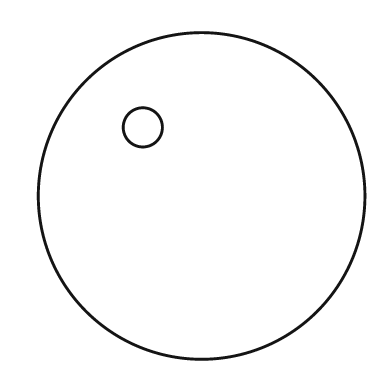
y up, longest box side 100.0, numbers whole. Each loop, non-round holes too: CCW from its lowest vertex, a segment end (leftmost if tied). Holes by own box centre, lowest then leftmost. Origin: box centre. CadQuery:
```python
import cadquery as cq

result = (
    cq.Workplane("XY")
    .moveTo(0.0, 0.0)
    .circle(50.0)
    .moveTo(-18.0, 21.0)
    .circle(6.0)
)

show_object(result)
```